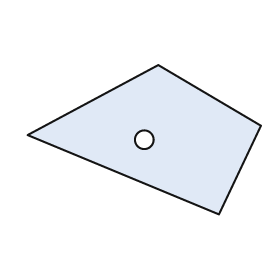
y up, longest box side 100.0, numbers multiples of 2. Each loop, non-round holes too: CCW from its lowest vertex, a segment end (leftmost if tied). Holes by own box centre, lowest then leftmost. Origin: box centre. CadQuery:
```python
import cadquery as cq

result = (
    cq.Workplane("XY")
    .moveTo(32.0, -32.0)
    .lineTo(50.0, 6.0)
    .lineTo(6.0, 32.0)
    .lineTo(-50.0, 2.0)
    .close()
    .moveTo(0.0, 0.0)
    .circle(4.0)
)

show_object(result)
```